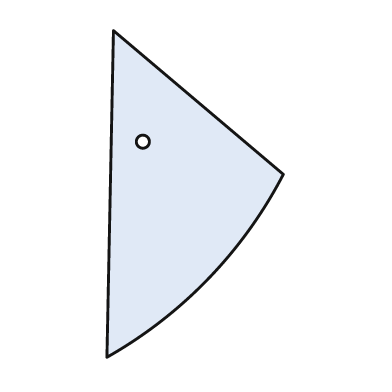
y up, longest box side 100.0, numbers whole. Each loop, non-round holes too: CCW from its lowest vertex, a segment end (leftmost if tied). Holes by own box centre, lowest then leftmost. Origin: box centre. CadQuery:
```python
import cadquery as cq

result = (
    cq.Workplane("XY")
    .moveTo(-27.0, -50.0)
    .threePointArc((4.0, -26.0), (27.0, 6.0))
    .lineTo(-25.0, 50.0)
    .close()
    .moveTo(-16.0, 16.0)
    .circle(2.0)
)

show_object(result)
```